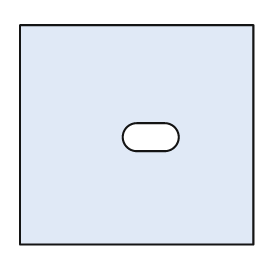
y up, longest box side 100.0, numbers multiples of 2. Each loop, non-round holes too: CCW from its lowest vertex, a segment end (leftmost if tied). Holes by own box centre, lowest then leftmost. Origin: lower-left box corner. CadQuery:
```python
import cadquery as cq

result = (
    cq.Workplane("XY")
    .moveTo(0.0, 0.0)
    .lineTo(100.0, 0.0)
    .lineTo(100.0, 94.0)
    .lineTo(0.0, 94.0)
    .close()
    .moveTo(50.0, 40.0)
    .lineTo(62.0, 40.0)
    .threePointArc((68.0, 46.0), (62.0, 52.0))
    .lineTo(50.0, 52.0)
    .threePointArc((44.0, 46.0), (50.0, 40.0))
    .close()
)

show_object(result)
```